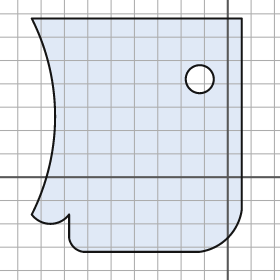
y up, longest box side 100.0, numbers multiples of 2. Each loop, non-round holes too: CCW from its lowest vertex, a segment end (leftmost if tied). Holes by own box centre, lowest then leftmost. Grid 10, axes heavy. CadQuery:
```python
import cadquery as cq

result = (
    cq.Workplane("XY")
    .moveTo(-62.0, -32.0)
    .lineTo(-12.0, -32.0)
    .threePointArc((0.0, -26.0), (6.0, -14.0))
    .lineTo(6.0, 68.0)
    .lineTo(-84.0, 68.0)
    .threePointArc((-74.0, 26.0), (-84.0, -16.0))
    .threePointArc((-76.0, -20.0), (-68.0, -16.0))
    .lineTo(-68.0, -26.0)
    .threePointArc((-66.0, -30.0), (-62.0, -32.0))
    .close()
    .moveTo(-12.0, 42.0)
    .circle(6.0)
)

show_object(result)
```